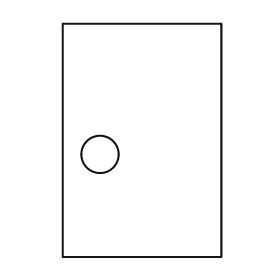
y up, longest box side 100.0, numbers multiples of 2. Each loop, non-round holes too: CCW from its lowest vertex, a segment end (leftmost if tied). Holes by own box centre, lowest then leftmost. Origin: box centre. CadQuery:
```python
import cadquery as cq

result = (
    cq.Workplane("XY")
    .moveTo(-34.0, -50.0)
    .lineTo(34.0, -50.0)
    .lineTo(34.0, 50.0)
    .lineTo(-34.0, 50.0)
    .close()
    .moveTo(-18.0, -6.0)
    .circle(8.0)
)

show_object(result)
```